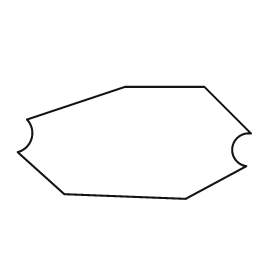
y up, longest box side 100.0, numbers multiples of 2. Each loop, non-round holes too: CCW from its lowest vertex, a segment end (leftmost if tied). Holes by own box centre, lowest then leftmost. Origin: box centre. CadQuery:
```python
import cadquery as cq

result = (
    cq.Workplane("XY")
    .moveTo(22.0, -24.0)
    .lineTo(48.0, -10.0)
    .threePointArc((42.0, -2.0), (50.0, 4.0))
    .lineTo(30.0, 24.0)
    .lineTo(-4.0, 24.0)
    .lineTo(-46.0, 10.0)
    .threePointArc((-44.0, 2.0), (-50.0, -4.0))
    .lineTo(-30.0, -22.0)
    .close()
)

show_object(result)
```